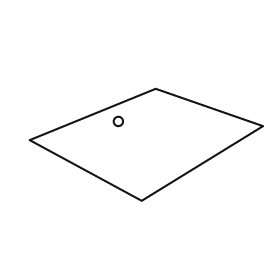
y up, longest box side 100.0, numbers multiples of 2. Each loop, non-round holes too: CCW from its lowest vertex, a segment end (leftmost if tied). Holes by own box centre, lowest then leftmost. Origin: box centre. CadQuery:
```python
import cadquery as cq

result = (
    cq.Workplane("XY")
    .moveTo(-2.0, -24.0)
    .lineTo(50.0, 8.0)
    .lineTo(4.0, 24.0)
    .lineTo(-50.0, 2.0)
    .close()
    .moveTo(-12.0, 10.0)
    .circle(2.0)
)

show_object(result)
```